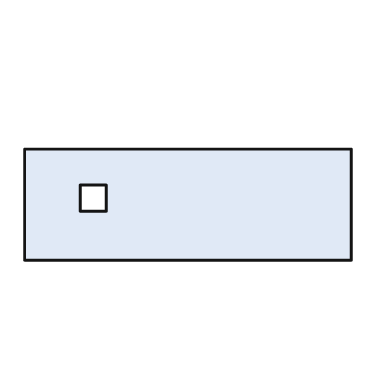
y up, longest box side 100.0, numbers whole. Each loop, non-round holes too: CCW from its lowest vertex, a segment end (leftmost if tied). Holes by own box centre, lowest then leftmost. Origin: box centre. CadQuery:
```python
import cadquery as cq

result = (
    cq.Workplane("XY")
    .moveTo(-50.0, -17.0)
    .lineTo(50.0, -17.0)
    .lineTo(50.0, 17.0)
    .lineTo(-50.0, 17.0)
    .close()
    .moveTo(-33.0, -2.0)
    .lineTo(-25.0, -2.0)
    .lineTo(-25.0, 6.0)
    .lineTo(-33.0, 6.0)
    .close()
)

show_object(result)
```